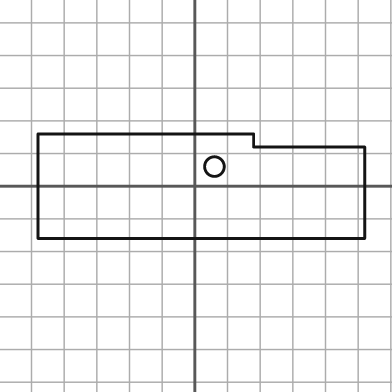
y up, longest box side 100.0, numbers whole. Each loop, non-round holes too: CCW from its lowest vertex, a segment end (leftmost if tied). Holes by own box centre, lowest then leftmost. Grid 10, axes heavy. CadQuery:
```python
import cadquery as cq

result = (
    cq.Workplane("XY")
    .moveTo(-48.0, -16.0)
    .lineTo(52.0, -16.0)
    .lineTo(52.0, 12.0)
    .lineTo(18.0, 12.0)
    .lineTo(18.0, 16.0)
    .lineTo(-48.0, 16.0)
    .close()
    .moveTo(6.0, 6.0)
    .circle(3.0)
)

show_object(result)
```